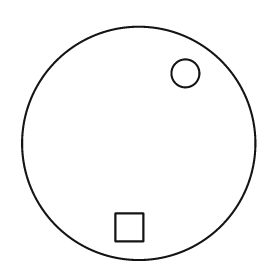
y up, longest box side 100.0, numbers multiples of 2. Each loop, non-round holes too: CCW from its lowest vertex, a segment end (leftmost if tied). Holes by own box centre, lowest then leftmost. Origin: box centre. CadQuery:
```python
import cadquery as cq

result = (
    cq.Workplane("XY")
    .moveTo(0.0, 0.0)
    .circle(50.0)
    .moveTo(-10.0, -42.0)
    .lineTo(2.0, -42.0)
    .lineTo(2.0, -30.0)
    .lineTo(-10.0, -30.0)
    .close()
    .moveTo(20.0, 30.0)
    .circle(6.0)
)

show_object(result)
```